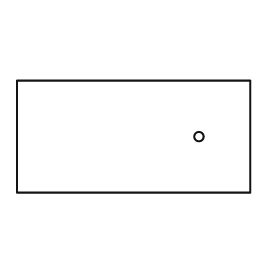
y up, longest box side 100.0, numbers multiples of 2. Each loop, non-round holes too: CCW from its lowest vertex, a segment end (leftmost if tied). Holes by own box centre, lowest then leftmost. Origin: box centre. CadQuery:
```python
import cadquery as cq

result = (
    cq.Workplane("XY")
    .moveTo(-50.0, -24.0)
    .lineTo(50.0, -24.0)
    .lineTo(50.0, 24.0)
    .lineTo(-50.0, 24.0)
    .close()
    .moveTo(28.0, 0.0)
    .circle(2.0)
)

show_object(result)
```